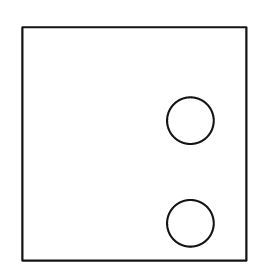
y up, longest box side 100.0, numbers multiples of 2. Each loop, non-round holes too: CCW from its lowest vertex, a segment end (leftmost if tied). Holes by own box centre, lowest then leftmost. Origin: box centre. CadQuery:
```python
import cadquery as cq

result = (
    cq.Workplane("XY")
    .moveTo(-48.0, -50.0)
    .lineTo(48.0, -50.0)
    .lineTo(48.0, 50.0)
    .lineTo(-48.0, 50.0)
    .close()
    .moveTo(24.0, -34.0)
    .circle(10.0)
    .moveTo(24.0, 10.0)
    .circle(10.0)
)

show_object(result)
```